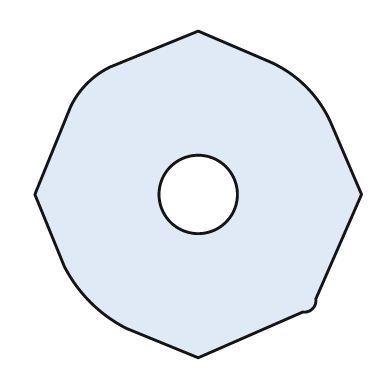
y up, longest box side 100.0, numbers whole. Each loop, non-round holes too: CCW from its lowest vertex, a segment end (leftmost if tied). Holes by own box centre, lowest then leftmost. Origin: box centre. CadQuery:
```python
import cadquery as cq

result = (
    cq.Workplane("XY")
    .moveTo(0.0, -50.0)
    .lineTo(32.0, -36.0)
    .threePointArc((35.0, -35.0), (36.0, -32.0))
    .lineTo(50.0, 0.0)
    .lineTo(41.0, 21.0)
    .threePointArc((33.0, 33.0), (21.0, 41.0))
    .lineTo(0.0, 50.0)
    .lineTo(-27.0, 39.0)
    .threePointArc((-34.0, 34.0), (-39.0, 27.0))
    .lineTo(-50.0, 0.0)
    .lineTo(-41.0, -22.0)
    .threePointArc((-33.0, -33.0), (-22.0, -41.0))
    .close()
    .moveTo(0.0, 0.0)
    .circle(12.0)
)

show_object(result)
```